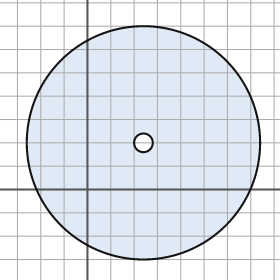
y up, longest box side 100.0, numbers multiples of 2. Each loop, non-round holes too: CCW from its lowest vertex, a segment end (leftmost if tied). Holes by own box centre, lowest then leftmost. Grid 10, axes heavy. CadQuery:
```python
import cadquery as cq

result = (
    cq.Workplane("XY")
    .moveTo(24.0, 20.0)
    .circle(50.0)
    .moveTo(24.0, 20.0)
    .circle(4.0)
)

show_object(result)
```